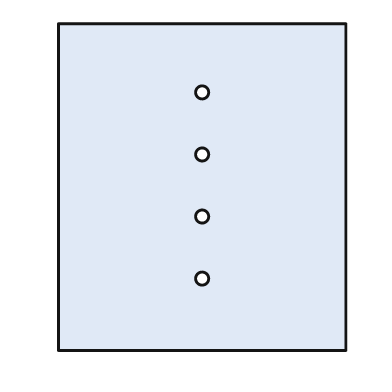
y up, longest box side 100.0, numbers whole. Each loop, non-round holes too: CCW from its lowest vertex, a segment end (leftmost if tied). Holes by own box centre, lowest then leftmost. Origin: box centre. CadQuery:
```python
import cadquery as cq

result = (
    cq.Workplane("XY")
    .moveTo(-44.0, -50.0)
    .lineTo(44.0, -50.0)
    .lineTo(44.0, 50.0)
    .lineTo(-44.0, 50.0)
    .close()
    .moveTo(0.0, -28.0)
    .circle(2.0)
    .moveTo(0.0, -9.0)
    .circle(2.0)
    .moveTo(0.0, 10.0)
    .circle(2.0)
    .moveTo(0.0, 29.0)
    .circle(2.0)
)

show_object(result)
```